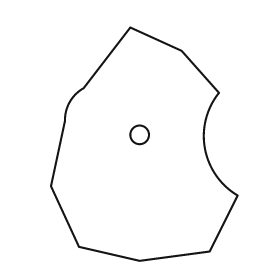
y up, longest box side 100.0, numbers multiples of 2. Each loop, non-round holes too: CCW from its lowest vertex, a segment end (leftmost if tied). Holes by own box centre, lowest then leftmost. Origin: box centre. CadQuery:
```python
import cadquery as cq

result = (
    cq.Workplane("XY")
    .moveTo(-2.0, -50.0)
    .lineTo(28.0, -46.0)
    .lineTo(40.0, -22.0)
    .threePointArc((26.0, -2.0), (32.0, 22.0))
    .lineTo(16.0, 40.0)
    .lineTo(-6.0, 50.0)
    .lineTo(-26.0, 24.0)
    .threePointArc((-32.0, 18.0), (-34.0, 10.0))
    .lineTo(-40.0, -18.0)
    .lineTo(-28.0, -44.0)
    .close()
    .moveTo(-2.0, 4.0)
    .circle(4.0)
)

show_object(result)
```